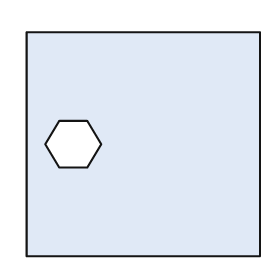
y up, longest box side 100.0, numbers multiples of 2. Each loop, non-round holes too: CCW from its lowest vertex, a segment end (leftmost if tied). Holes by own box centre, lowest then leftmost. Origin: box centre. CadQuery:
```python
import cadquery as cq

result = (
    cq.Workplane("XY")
    .moveTo(-50.0, -48.0)
    .lineTo(50.0, -48.0)
    .lineTo(50.0, 48.0)
    .lineTo(-50.0, 48.0)
    .close()
    .moveTo(-36.0, -10.0)
    .lineTo(-24.0, -10.0)
    .lineTo(-18.0, 0.0)
    .lineTo(-24.0, 10.0)
    .lineTo(-36.0, 10.0)
    .lineTo(-42.0, 0.0)
    .close()
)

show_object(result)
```